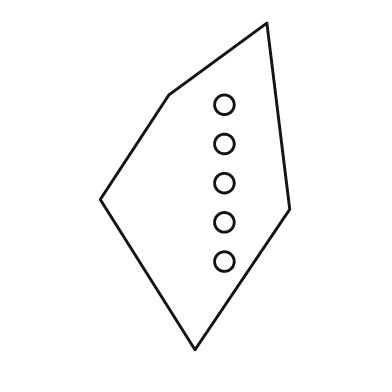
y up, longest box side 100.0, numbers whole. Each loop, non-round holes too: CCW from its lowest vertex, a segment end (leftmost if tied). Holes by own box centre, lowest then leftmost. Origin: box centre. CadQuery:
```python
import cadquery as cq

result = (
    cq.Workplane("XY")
    .moveTo(0.0, -50.0)
    .lineTo(29.0, -7.0)
    .lineTo(22.0, 50.0)
    .lineTo(-8.0, 28.0)
    .lineTo(-29.0, -4.0)
    .close()
    .moveTo(9.0, -23.0)
    .circle(3.0)
    .moveTo(9.0, -11.0)
    .circle(3.0)
    .moveTo(9.0, 1.0)
    .circle(3.0)
    .moveTo(9.0, 13.0)
    .circle(3.0)
    .moveTo(9.0, 25.0)
    .circle(3.0)
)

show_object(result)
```